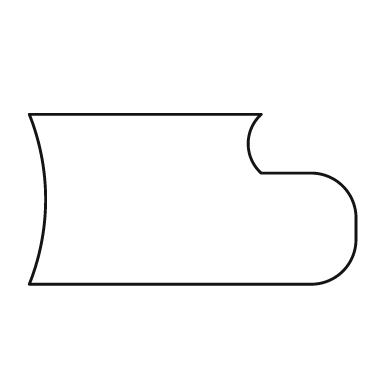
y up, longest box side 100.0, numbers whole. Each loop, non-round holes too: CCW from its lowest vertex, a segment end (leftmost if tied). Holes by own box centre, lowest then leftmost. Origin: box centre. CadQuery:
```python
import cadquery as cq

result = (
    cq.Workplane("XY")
    .moveTo(-50.0, -26.0)
    .lineTo(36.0, -26.0)
    .threePointArc((46.0, -22.0), (50.0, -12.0))
    .lineTo(50.0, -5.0)
    .threePointArc((46.0, 4.0), (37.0, 8.0))
    .lineTo(21.0, 8.0)
    .threePointArc((17.0, 17.0), (21.0, 26.0))
    .lineTo(-50.0, 26.0)
    .threePointArc((-45.0, 0.0), (-50.0, -26.0))
    .close()
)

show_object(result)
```